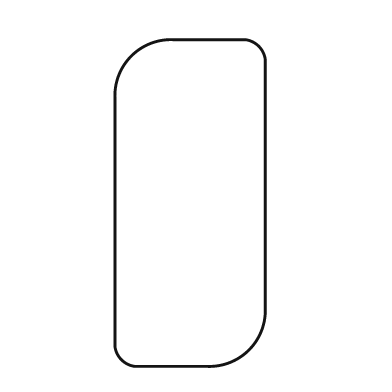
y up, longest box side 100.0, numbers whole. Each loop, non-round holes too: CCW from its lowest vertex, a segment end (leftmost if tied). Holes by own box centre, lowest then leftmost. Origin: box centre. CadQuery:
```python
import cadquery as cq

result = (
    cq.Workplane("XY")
    .moveTo(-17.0, -50.0)
    .lineTo(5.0, -50.0)
    .threePointArc((18.0, -45.0), (23.0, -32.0))
    .lineTo(23.0, 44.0)
    .threePointArc((21.0, 48.0), (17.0, 50.0))
    .lineTo(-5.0, 50.0)
    .threePointArc((-18.0, 45.0), (-23.0, 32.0))
    .lineTo(-23.0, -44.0)
    .threePointArc((-21.0, -48.0), (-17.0, -50.0))
    .close()
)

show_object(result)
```